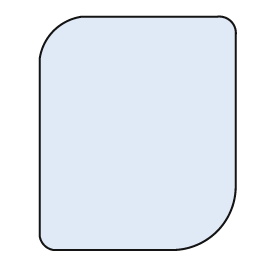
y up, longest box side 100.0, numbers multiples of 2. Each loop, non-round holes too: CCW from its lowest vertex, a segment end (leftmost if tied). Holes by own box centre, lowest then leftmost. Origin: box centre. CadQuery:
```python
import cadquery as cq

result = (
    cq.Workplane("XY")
    .moveTo(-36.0, -50.0)
    .lineTo(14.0, -50.0)
    .threePointArc((34.0, -42.0), (42.0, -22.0))
    .lineTo(42.0, 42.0)
    .threePointArc((40.0, 48.0), (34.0, 50.0))
    .lineTo(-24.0, 50.0)
    .threePointArc((-36.0, 44.0), (-42.0, 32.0))
    .lineTo(-42.0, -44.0)
    .threePointArc((-40.0, -48.0), (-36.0, -50.0))
    .close()
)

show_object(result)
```